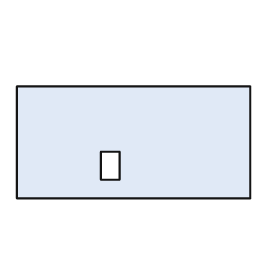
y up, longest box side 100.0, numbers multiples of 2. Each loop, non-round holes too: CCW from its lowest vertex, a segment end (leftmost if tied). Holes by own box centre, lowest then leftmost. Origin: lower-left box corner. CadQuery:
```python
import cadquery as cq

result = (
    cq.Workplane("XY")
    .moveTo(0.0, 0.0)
    .lineTo(100.0, 0.0)
    .lineTo(100.0, 48.0)
    .lineTo(0.0, 48.0)
    .close()
    .moveTo(36.0, 8.0)
    .lineTo(44.0, 8.0)
    .lineTo(44.0, 20.0)
    .lineTo(36.0, 20.0)
    .close()
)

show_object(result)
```